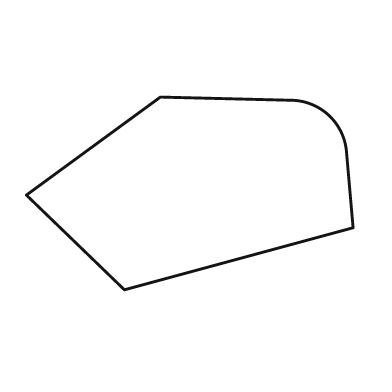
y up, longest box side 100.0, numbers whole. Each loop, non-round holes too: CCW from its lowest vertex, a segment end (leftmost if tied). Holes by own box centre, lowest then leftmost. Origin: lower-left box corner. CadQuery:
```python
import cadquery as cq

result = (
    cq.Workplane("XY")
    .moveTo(30.0, 0.0)
    .lineTo(100.0, 19.0)
    .lineTo(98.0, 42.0)
    .threePointArc((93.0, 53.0), (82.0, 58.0))
    .lineTo(41.0, 59.0)
    .lineTo(0.0, 29.0)
    .close()
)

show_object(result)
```